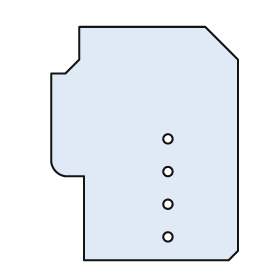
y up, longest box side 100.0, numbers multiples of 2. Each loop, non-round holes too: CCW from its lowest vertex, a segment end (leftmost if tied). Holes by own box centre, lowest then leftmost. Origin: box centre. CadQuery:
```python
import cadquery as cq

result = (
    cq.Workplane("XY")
    .moveTo(-26.0, -50.0)
    .lineTo(36.0, -50.0)
    .lineTo(40.0, -46.0)
    .lineTo(40.0, 36.0)
    .lineTo(26.0, 50.0)
    .lineTo(-28.0, 50.0)
    .lineTo(-28.0, 36.0)
    .lineTo(-34.0, 30.0)
    .lineTo(-40.0, 30.0)
    .lineTo(-40.0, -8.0)
    .threePointArc((-38.0, -12.0), (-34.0, -14.0))
    .lineTo(-26.0, -14.0)
    .close()
    .moveTo(10.0, -40.0)
    .circle(2.0)
    .moveTo(10.0, -26.0)
    .circle(2.0)
    .moveTo(10.0, -12.0)
    .circle(2.0)
    .moveTo(10.0, 2.0)
    .circle(2.0)
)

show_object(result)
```